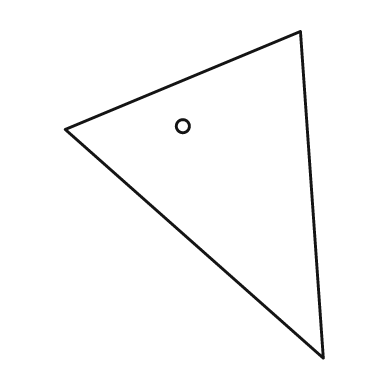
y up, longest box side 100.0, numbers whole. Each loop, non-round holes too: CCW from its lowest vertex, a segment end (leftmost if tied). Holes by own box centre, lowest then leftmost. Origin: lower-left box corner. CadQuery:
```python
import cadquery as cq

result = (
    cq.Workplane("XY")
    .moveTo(79.0, 0.0)
    .lineTo(72.0, 100.0)
    .lineTo(0.0, 70.0)
    .close()
    .moveTo(36.0, 71.0)
    .circle(2.0)
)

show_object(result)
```